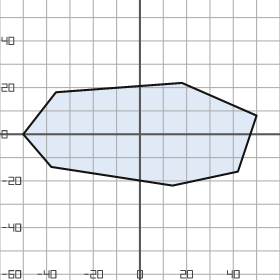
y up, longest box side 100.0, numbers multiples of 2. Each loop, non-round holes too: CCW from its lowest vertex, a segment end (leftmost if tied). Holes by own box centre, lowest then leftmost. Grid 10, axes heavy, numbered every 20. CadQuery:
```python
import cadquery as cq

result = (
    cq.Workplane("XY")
    .moveTo(14.0, -22.0)
    .lineTo(42.0, -16.0)
    .lineTo(50.0, 8.0)
    .lineTo(18.0, 22.0)
    .lineTo(-36.0, 18.0)
    .lineTo(-50.0, 0.0)
    .lineTo(-38.0, -14.0)
    .close()
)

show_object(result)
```